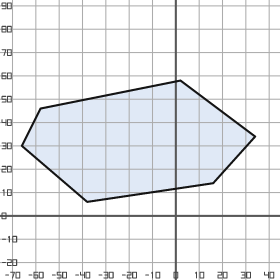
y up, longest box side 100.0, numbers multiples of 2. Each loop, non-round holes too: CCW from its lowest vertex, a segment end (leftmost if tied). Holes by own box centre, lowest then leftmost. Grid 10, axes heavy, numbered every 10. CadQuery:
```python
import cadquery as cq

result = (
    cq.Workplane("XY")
    .moveTo(-38.0, 6.0)
    .lineTo(16.0, 14.0)
    .lineTo(34.0, 34.0)
    .lineTo(2.0, 58.0)
    .lineTo(-58.0, 46.0)
    .lineTo(-66.0, 30.0)
    .close()
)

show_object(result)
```